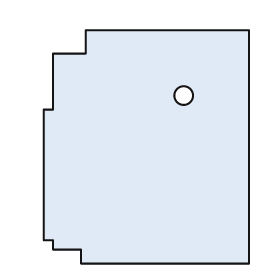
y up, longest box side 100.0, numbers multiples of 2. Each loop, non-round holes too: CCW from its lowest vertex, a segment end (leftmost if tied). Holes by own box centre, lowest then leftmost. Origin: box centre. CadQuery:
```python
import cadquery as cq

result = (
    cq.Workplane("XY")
    .moveTo(-28.0, -50.0)
    .lineTo(44.0, -50.0)
    .lineTo(44.0, 50.0)
    .lineTo(-26.0, 50.0)
    .lineTo(-26.0, 40.0)
    .lineTo(-40.0, 40.0)
    .lineTo(-40.0, 16.0)
    .lineTo(-44.0, 16.0)
    .lineTo(-44.0, -40.0)
    .lineTo(-40.0, -40.0)
    .lineTo(-40.0, -44.0)
    .lineTo(-28.0, -44.0)
    .close()
    .moveTo(16.0, 22.0)
    .circle(4.0)
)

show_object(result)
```